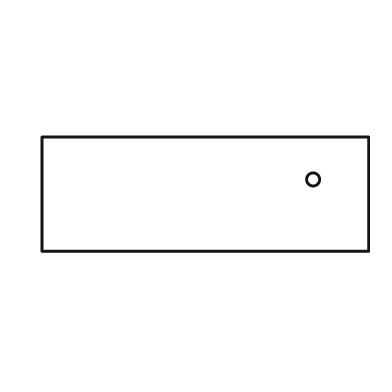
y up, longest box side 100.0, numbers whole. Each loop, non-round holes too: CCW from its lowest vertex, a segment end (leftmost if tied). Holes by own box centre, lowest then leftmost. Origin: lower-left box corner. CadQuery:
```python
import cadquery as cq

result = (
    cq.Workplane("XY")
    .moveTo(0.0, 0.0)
    .lineTo(100.0, 0.0)
    .lineTo(100.0, 35.0)
    .lineTo(0.0, 35.0)
    .close()
    .moveTo(83.0, 22.0)
    .circle(2.0)
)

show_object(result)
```